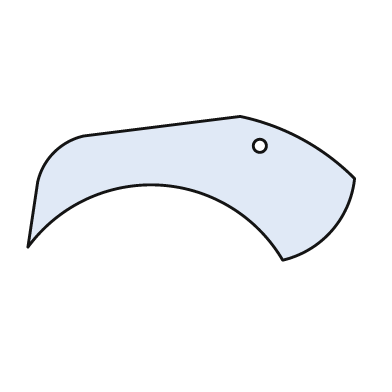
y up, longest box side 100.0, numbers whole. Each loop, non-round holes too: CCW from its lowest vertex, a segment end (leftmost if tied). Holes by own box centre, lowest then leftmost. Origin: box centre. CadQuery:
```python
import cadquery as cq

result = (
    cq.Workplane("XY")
    .moveTo(28.0, -22.0)
    .threePointArc((43.0, -13.0), (50.0, 3.0))
    .threePointArc((34.0, 15.0), (15.0, 22.0))
    .lineTo(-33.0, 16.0)
    .threePointArc((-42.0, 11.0), (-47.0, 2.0))
    .lineTo(-50.0, -18.0)
    .threePointArc((-10.0, 1.0), (28.0, -22.0))
    .close()
    .moveTo(21.0, 13.0)
    .circle(2.0)
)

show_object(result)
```